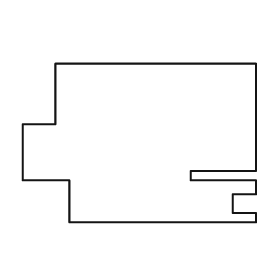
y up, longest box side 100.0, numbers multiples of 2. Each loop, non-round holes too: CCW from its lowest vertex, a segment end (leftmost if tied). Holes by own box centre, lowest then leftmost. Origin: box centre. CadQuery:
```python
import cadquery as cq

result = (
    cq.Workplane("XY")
    .moveTo(-30.0, -34.0)
    .lineTo(50.0, -34.0)
    .lineTo(50.0, -30.0)
    .lineTo(40.0, -30.0)
    .lineTo(40.0, -22.0)
    .lineTo(50.0, -22.0)
    .lineTo(50.0, -16.0)
    .lineTo(22.0, -16.0)
    .lineTo(22.0, -12.0)
    .lineTo(50.0, -12.0)
    .lineTo(50.0, 34.0)
    .lineTo(-36.0, 34.0)
    .lineTo(-36.0, 8.0)
    .lineTo(-50.0, 8.0)
    .lineTo(-50.0, -16.0)
    .lineTo(-30.0, -16.0)
    .close()
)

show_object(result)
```